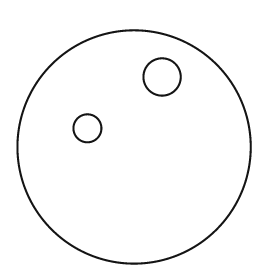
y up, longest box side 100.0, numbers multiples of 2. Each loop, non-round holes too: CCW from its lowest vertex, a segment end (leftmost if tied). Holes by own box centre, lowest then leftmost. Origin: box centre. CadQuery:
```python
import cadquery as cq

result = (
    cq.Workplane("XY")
    .moveTo(0.0, 0.0)
    .circle(50.0)
    .moveTo(-20.0, 8.0)
    .circle(6.0)
    .moveTo(12.0, 30.0)
    .circle(8.0)
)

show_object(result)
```